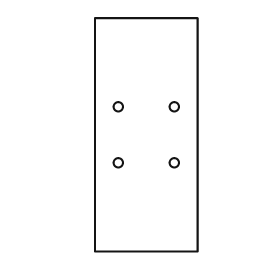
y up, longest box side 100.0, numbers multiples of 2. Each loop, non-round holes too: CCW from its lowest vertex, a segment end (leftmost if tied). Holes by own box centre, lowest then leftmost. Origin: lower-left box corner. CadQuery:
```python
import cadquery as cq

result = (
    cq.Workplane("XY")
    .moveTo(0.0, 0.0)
    .lineTo(44.0, 0.0)
    .lineTo(44.0, 100.0)
    .lineTo(0.0, 100.0)
    .close()
    .moveTo(10.0, 38.0)
    .circle(2.0)
    .moveTo(34.0, 38.0)
    .circle(2.0)
    .moveTo(10.0, 62.0)
    .circle(2.0)
    .moveTo(34.0, 62.0)
    .circle(2.0)
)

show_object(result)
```